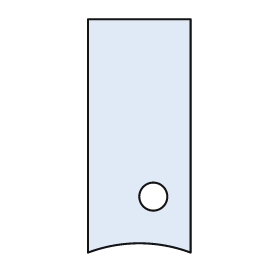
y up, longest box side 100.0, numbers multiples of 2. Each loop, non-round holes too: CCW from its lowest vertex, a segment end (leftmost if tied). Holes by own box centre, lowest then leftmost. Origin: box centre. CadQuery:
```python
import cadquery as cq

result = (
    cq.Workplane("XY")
    .moveTo(-22.0, -50.0)
    .threePointArc((0.0, -46.0), (22.0, -50.0))
    .lineTo(22.0, 50.0)
    .lineTo(-22.0, 50.0)
    .close()
    .moveTo(6.0, -26.0)
    .circle(6.0)
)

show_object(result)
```